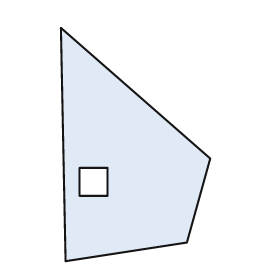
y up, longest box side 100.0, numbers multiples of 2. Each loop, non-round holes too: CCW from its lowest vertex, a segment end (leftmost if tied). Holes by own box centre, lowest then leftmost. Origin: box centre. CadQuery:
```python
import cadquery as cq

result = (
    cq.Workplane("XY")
    .moveTo(-30.0, -50.0)
    .lineTo(22.0, -42.0)
    .lineTo(32.0, -6.0)
    .lineTo(-32.0, 50.0)
    .close()
    .moveTo(-24.0, -22.0)
    .lineTo(-12.0, -22.0)
    .lineTo(-12.0, -10.0)
    .lineTo(-24.0, -10.0)
    .close()
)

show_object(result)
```